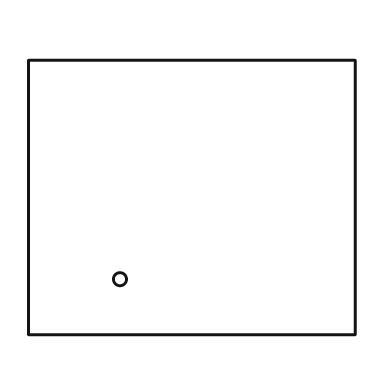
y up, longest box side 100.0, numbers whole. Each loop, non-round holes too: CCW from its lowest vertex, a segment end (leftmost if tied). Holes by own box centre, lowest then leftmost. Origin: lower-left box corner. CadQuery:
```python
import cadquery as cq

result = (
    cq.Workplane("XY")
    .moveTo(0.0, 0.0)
    .lineTo(100.0, 0.0)
    .lineTo(100.0, 84.0)
    .lineTo(0.0, 84.0)
    .close()
    .moveTo(28.0, 17.0)
    .circle(2.0)
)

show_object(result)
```